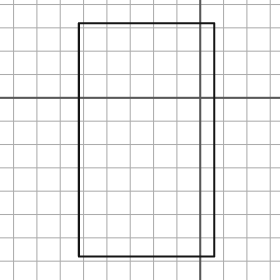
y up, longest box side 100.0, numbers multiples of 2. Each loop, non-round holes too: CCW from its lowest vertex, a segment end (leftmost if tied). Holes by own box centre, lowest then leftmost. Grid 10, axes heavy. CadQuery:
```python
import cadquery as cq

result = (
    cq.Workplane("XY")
    .moveTo(-52.0, -68.0)
    .lineTo(6.0, -68.0)
    .lineTo(6.0, 32.0)
    .lineTo(-52.0, 32.0)
    .close()
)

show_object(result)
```